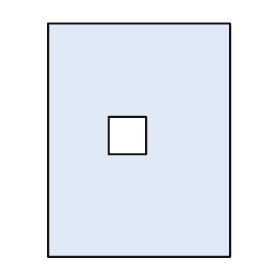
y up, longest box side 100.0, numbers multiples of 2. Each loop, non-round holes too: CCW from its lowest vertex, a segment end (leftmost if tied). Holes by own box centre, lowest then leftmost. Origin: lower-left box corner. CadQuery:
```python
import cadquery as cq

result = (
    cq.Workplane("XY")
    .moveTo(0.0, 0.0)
    .lineTo(78.0, 0.0)
    .lineTo(78.0, 100.0)
    .lineTo(0.0, 100.0)
    .close()
    .moveTo(26.0, 44.0)
    .lineTo(42.0, 44.0)
    .lineTo(42.0, 60.0)
    .lineTo(26.0, 60.0)
    .close()
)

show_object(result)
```